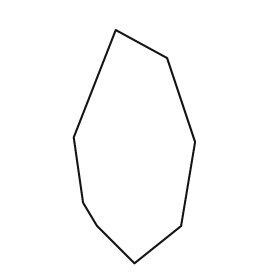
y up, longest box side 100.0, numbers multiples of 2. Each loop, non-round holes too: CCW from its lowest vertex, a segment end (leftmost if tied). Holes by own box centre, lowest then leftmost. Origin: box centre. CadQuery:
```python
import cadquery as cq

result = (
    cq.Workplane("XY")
    .moveTo(0.0, -50.0)
    .lineTo(20.0, -34.0)
    .lineTo(26.0, 2.0)
    .lineTo(14.0, 38.0)
    .lineTo(-8.0, 50.0)
    .lineTo(-26.0, 4.0)
    .lineTo(-22.0, -24.0)
    .lineTo(-16.0, -34.0)
    .close()
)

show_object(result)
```